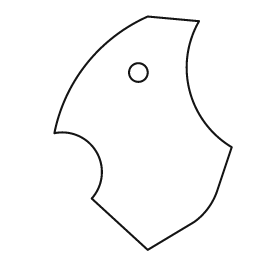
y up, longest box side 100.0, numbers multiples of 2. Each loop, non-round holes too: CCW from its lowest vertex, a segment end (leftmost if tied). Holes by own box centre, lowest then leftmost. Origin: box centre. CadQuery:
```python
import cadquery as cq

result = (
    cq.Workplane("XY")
    .moveTo(2.0, -50.0)
    .lineTo(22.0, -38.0)
    .threePointArc((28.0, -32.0), (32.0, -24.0))
    .lineTo(38.0, -6.0)
    .threePointArc((20.0, 18.0), (24.0, 48.0))
    .lineTo(2.0, 50.0)
    .threePointArc((-24.0, 30.0), (-38.0, 0.0))
    .threePointArc((-20.0, -8.0), (-22.0, -28.0))
    .close()
    .moveTo(-2.0, 26.0)
    .circle(4.0)
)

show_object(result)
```